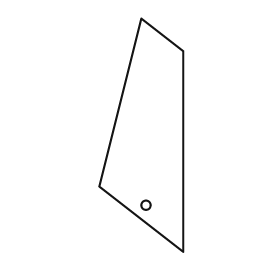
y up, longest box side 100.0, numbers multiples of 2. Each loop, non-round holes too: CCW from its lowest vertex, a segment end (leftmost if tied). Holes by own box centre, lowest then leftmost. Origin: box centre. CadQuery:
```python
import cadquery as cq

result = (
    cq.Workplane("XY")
    .moveTo(18.0, -50.0)
    .lineTo(18.0, 36.0)
    .lineTo(0.0, 50.0)
    .lineTo(-18.0, -22.0)
    .close()
    .moveTo(2.0, -30.0)
    .circle(2.0)
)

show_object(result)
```